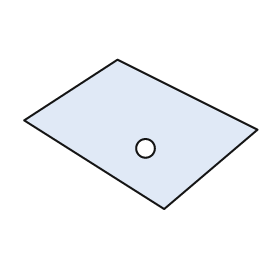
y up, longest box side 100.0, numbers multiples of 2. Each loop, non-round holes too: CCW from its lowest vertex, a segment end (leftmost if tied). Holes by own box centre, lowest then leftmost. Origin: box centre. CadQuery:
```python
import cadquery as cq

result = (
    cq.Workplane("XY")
    .moveTo(10.0, -32.0)
    .lineTo(50.0, 2.0)
    .lineTo(-10.0, 32.0)
    .lineTo(-50.0, 6.0)
    .close()
    .moveTo(2.0, -6.0)
    .circle(4.0)
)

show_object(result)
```